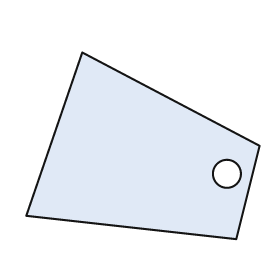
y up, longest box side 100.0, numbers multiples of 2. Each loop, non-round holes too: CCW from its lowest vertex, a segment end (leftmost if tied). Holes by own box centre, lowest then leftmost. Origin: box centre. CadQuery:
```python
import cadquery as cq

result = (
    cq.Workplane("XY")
    .moveTo(40.0, -40.0)
    .lineTo(50.0, 0.0)
    .lineTo(-26.0, 40.0)
    .lineTo(-50.0, -30.0)
    .close()
    .moveTo(36.0, -12.0)
    .circle(6.0)
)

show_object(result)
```